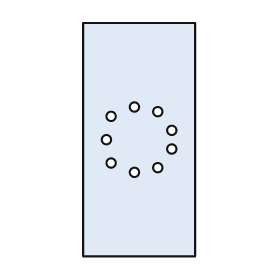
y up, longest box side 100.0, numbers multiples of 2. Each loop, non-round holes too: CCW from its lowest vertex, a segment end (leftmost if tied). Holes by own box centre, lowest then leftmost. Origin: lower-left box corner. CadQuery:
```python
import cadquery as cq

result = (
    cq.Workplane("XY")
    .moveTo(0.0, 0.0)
    .lineTo(48.0, 0.0)
    .lineTo(48.0, 100.0)
    .lineTo(0.0, 100.0)
    .close()
    .moveTo(22.0, 36.0)
    .circle(2.0)
    .moveTo(32.0, 38.0)
    .circle(2.0)
    .moveTo(12.0, 40.0)
    .circle(2.0)
    .moveTo(38.0, 46.0)
    .circle(2.0)
    .moveTo(10.0, 50.0)
    .circle(2.0)
    .moveTo(38.0, 54.0)
    .circle(2.0)
    .moveTo(12.0, 60.0)
    .circle(2.0)
    .moveTo(32.0, 62.0)
    .circle(2.0)
    .moveTo(22.0, 64.0)
    .circle(2.0)
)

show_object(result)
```